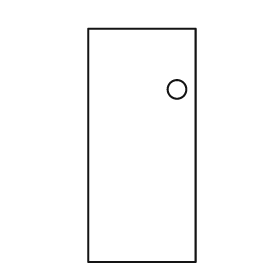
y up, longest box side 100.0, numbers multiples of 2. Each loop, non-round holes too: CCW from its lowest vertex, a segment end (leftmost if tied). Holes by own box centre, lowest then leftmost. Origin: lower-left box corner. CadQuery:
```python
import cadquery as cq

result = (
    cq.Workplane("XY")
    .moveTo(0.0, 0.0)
    .lineTo(46.0, 0.0)
    .lineTo(46.0, 100.0)
    .lineTo(0.0, 100.0)
    .close()
    .moveTo(38.0, 74.0)
    .circle(4.0)
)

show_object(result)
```